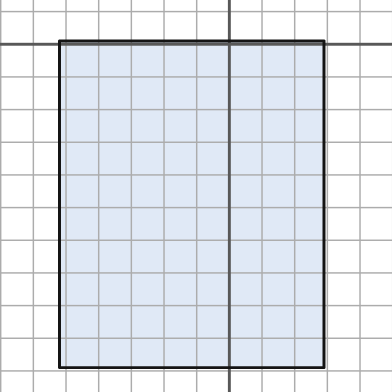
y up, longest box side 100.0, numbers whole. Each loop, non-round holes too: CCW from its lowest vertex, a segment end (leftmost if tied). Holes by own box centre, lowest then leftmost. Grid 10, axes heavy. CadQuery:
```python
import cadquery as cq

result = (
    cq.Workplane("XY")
    .moveTo(-52.0, -99.0)
    .lineTo(29.0, -99.0)
    .lineTo(29.0, 1.0)
    .lineTo(-52.0, 1.0)
    .close()
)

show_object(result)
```